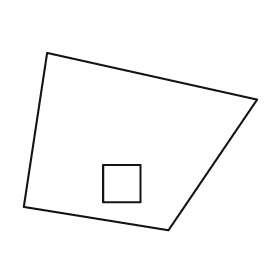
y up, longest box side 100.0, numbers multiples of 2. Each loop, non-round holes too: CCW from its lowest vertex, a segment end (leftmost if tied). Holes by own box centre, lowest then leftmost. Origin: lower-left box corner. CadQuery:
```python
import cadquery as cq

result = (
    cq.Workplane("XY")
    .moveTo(62.0, 0.0)
    .lineTo(100.0, 56.0)
    .lineTo(10.0, 76.0)
    .lineTo(0.0, 10.0)
    .close()
    .moveTo(34.0, 12.0)
    .lineTo(50.0, 12.0)
    .lineTo(50.0, 28.0)
    .lineTo(34.0, 28.0)
    .close()
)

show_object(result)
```